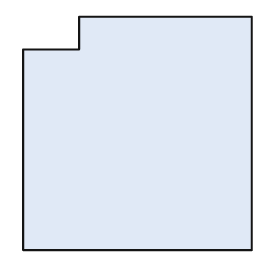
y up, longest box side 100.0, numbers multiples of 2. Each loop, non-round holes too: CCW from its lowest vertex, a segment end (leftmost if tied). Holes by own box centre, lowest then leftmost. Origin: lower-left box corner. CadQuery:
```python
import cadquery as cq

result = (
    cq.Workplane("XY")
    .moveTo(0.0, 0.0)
    .lineTo(98.0, 0.0)
    .lineTo(98.0, 100.0)
    .lineTo(24.0, 100.0)
    .lineTo(24.0, 86.0)
    .lineTo(0.0, 86.0)
    .close()
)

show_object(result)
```